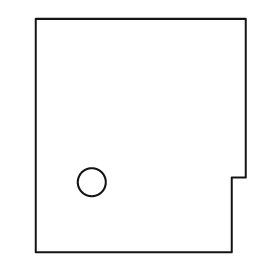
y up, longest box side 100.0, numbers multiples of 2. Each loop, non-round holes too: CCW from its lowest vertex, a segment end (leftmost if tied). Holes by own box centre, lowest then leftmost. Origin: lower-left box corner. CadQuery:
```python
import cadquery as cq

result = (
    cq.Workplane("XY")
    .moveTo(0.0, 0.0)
    .lineTo(84.0, 0.0)
    .lineTo(84.0, 32.0)
    .lineTo(90.0, 32.0)
    .lineTo(90.0, 100.0)
    .lineTo(0.0, 100.0)
    .close()
    .moveTo(24.0, 30.0)
    .circle(6.0)
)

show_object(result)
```